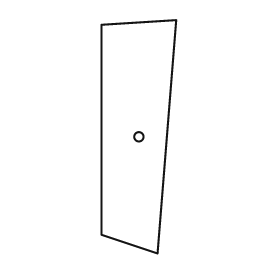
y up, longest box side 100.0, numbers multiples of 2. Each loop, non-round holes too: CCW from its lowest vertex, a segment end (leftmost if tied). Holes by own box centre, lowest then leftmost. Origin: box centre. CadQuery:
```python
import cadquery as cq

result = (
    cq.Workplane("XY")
    .moveTo(8.0, -50.0)
    .lineTo(16.0, 50.0)
    .lineTo(-16.0, 48.0)
    .lineTo(-16.0, -42.0)
    .close()
    .moveTo(0.0, 0.0)
    .circle(2.0)
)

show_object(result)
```